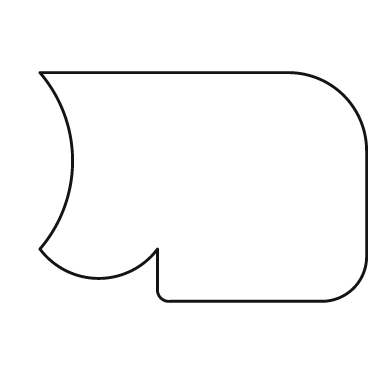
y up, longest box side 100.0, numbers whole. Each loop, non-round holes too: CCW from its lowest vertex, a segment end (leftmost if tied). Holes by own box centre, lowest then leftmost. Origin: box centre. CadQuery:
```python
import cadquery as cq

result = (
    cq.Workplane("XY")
    .moveTo(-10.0, -35.0)
    .lineTo(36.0, -35.0)
    .threePointArc((46.0, -31.0), (50.0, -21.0))
    .lineTo(50.0, 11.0)
    .threePointArc((43.0, 28.0), (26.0, 35.0))
    .lineTo(-50.0, 35.0)
    .threePointArc((-40.0, 8.0), (-50.0, -19.0))
    .threePointArc((-32.0, -28.0), (-14.0, -19.0))
    .lineTo(-14.0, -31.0)
    .threePointArc((-13.0, -34.0), (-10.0, -35.0))
    .close()
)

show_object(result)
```